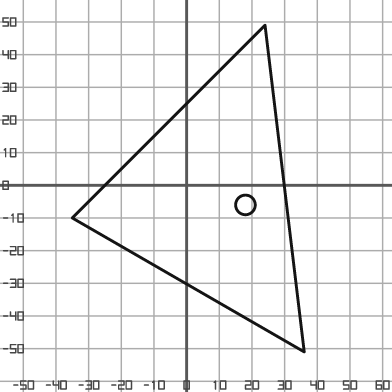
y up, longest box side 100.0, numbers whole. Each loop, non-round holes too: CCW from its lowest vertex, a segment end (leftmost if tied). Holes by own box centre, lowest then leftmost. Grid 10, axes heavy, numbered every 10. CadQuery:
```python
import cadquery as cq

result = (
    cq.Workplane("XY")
    .moveTo(36.0, -51.0)
    .lineTo(24.0, 49.0)
    .lineTo(-35.0, -10.0)
    .close()
    .moveTo(18.0, -6.0)
    .circle(3.0)
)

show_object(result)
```